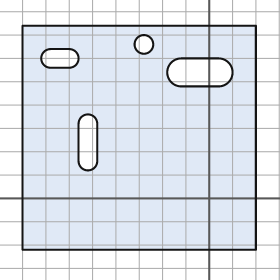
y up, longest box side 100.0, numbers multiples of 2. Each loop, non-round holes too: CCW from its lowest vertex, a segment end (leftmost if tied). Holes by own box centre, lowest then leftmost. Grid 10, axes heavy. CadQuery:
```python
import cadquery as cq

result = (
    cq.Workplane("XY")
    .moveTo(-80.0, -22.0)
    .lineTo(20.0, -22.0)
    .lineTo(20.0, 74.0)
    .lineTo(-80.0, 74.0)
    .close()
    .moveTo(-56.0, 16.0)
    .threePointArc((-52.0, 12.0), (-48.0, 16.0))
    .lineTo(-48.0, 32.0)
    .threePointArc((-52.0, 36.0), (-56.0, 32.0))
    .close()
    .moveTo(-12.0, 48.0)
    .lineTo(4.0, 48.0)
    .threePointArc((10.0, 54.0), (4.0, 60.0))
    .lineTo(-12.0, 60.0)
    .threePointArc((-18.0, 54.0), (-12.0, 48.0))
    .close()
    .moveTo(-68.0, 56.0)
    .lineTo(-60.0, 56.0)
    .threePointArc((-56.0, 60.0), (-60.0, 64.0))
    .lineTo(-68.0, 64.0)
    .threePointArc((-72.0, 60.0), (-68.0, 56.0))
    .close()
    .moveTo(-28.0, 66.0)
    .circle(4.0)
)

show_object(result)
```